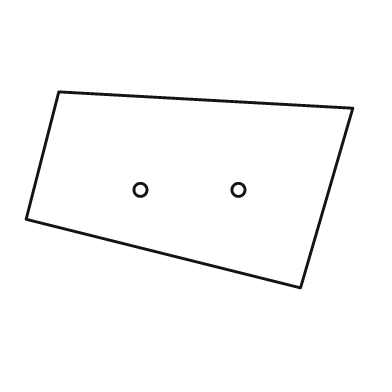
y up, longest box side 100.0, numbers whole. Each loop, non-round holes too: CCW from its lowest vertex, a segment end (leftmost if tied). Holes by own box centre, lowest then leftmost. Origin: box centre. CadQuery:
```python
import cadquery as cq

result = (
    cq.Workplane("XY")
    .moveTo(34.0, -30.0)
    .lineTo(50.0, 25.0)
    .lineTo(-40.0, 30.0)
    .lineTo(-50.0, -9.0)
    .close()
    .moveTo(-15.0, 0.0)
    .circle(2.0)
    .moveTo(15.0, 0.0)
    .circle(2.0)
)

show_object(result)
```